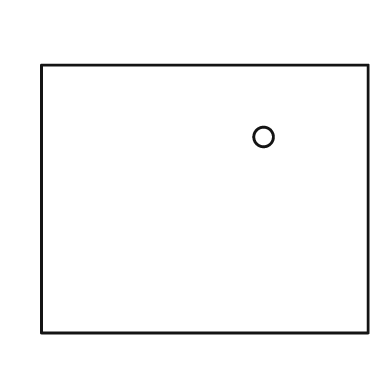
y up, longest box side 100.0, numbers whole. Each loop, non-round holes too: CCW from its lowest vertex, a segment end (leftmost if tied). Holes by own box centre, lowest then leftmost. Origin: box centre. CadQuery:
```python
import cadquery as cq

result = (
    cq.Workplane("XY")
    .moveTo(-50.0, -41.0)
    .lineTo(50.0, -41.0)
    .lineTo(50.0, 41.0)
    .lineTo(-50.0, 41.0)
    .close()
    .moveTo(18.0, 19.0)
    .circle(3.0)
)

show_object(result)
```